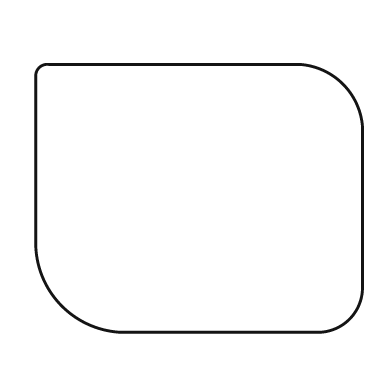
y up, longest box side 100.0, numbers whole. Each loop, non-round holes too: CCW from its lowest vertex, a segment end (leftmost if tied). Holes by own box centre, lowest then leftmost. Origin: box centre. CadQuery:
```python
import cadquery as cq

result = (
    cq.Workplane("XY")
    .moveTo(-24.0, -41.0)
    .lineTo(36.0, -41.0)
    .threePointArc((46.0, -37.0), (50.0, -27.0))
    .lineTo(50.0, 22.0)
    .threePointArc((44.0, 35.0), (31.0, 41.0))
    .lineTo(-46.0, 41.0)
    .threePointArc((-49.0, 40.0), (-50.0, 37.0))
    .lineTo(-50.0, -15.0)
    .threePointArc((-42.0, -33.0), (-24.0, -41.0))
    .close()
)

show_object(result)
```